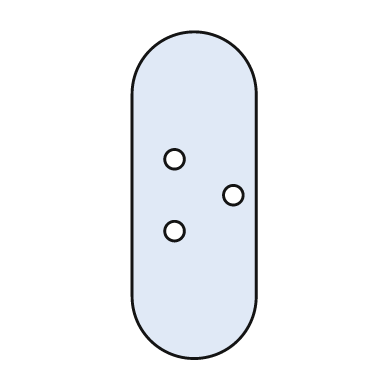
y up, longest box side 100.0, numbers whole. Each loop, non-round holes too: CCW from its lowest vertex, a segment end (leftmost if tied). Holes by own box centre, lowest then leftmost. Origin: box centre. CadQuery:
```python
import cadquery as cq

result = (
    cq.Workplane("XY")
    .moveTo(-19.0, -31.0)
    .threePointArc((0.0, -50.0), (19.0, -31.0))
    .lineTo(19.0, 31.0)
    .threePointArc((0.0, 50.0), (-19.0, 31.0))
    .close()
    .moveTo(-6.0, -11.0)
    .circle(3.0)
    .moveTo(12.0, 0.0)
    .circle(3.0)
    .moveTo(-6.0, 11.0)
    .circle(3.0)
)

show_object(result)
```